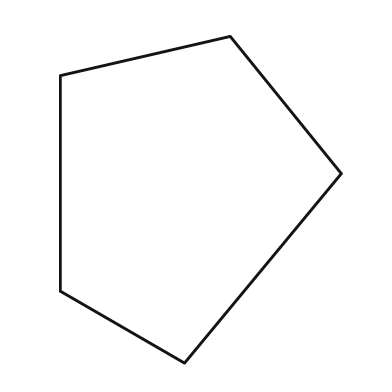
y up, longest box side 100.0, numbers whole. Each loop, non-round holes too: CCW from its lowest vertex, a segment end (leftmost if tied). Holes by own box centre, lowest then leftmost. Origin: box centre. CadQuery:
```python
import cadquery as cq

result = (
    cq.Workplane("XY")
    .moveTo(-5.0, -50.0)
    .lineTo(43.0, 8.0)
    .lineTo(9.0, 50.0)
    .lineTo(-43.0, 38.0)
    .lineTo(-43.0, -28.0)
    .close()
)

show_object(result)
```